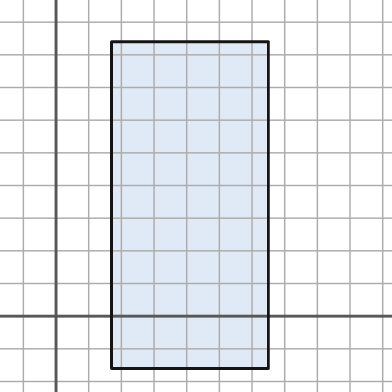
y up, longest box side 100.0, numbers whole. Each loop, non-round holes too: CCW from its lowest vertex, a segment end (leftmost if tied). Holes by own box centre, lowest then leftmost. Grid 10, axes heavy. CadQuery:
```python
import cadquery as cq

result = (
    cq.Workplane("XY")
    .moveTo(17.0, -16.0)
    .lineTo(65.0, -16.0)
    .lineTo(65.0, 84.0)
    .lineTo(17.0, 84.0)
    .close()
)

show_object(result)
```